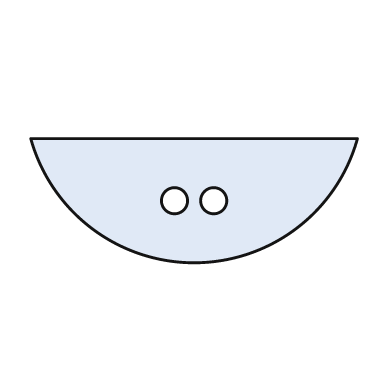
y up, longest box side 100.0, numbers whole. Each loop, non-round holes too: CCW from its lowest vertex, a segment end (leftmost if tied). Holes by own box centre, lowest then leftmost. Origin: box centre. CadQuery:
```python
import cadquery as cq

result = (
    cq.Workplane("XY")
    .moveTo(-50.0, 19.0)
    .threePointArc((0.0, -19.0), (50.0, 19.0))
    .close()
    .moveTo(-6.0, 0.0)
    .circle(4.0)
    .moveTo(6.0, 0.0)
    .circle(4.0)
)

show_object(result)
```